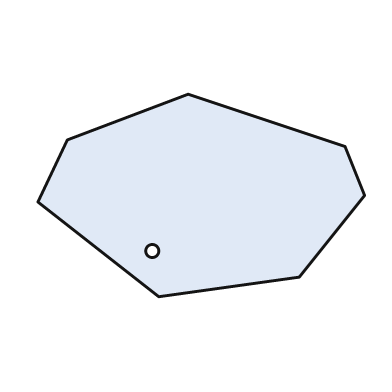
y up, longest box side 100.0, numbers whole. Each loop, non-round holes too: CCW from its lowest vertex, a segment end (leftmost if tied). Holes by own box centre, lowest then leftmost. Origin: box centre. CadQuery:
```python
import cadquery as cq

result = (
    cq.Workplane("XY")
    .moveTo(-13.0, -31.0)
    .lineTo(30.0, -25.0)
    .lineTo(50.0, 0.0)
    .lineTo(44.0, 15.0)
    .lineTo(-4.0, 31.0)
    .lineTo(-41.0, 17.0)
    .lineTo(-50.0, -2.0)
    .close()
    .moveTo(-15.0, -17.0)
    .circle(2.0)
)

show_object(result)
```